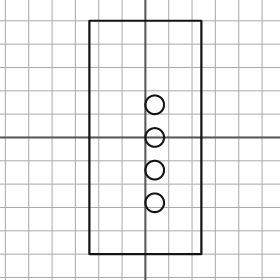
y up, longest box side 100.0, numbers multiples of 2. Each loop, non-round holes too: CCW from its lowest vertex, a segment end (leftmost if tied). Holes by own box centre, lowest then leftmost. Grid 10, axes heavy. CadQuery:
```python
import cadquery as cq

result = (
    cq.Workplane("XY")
    .moveTo(-24.0, -50.0)
    .lineTo(24.0, -50.0)
    .lineTo(24.0, 50.0)
    .lineTo(-24.0, 50.0)
    .close()
    .moveTo(4.0, -28.0)
    .circle(4.0)
    .moveTo(4.0, -14.0)
    .circle(4.0)
    .moveTo(4.0, 0.0)
    .circle(4.0)
    .moveTo(4.0, 14.0)
    .circle(4.0)
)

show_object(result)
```